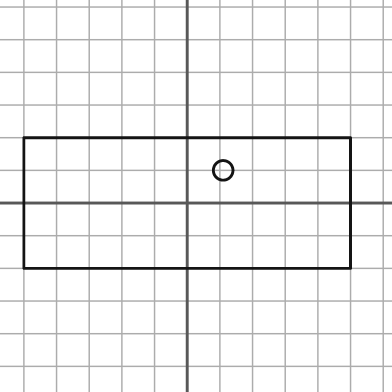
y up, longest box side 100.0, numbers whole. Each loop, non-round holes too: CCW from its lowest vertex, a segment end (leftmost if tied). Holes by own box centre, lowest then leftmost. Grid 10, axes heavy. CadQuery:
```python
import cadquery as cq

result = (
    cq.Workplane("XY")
    .moveTo(-50.0, -20.0)
    .lineTo(50.0, -20.0)
    .lineTo(50.0, 20.0)
    .lineTo(-50.0, 20.0)
    .close()
    .moveTo(11.0, 10.0)
    .circle(3.0)
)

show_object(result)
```